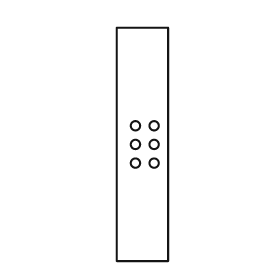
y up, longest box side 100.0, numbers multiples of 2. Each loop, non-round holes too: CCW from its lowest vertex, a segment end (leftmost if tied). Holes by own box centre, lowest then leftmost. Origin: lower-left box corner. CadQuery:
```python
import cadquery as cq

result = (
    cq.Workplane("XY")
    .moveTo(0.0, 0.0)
    .lineTo(22.0, 0.0)
    .lineTo(22.0, 100.0)
    .lineTo(0.0, 100.0)
    .close()
    .moveTo(8.0, 42.0)
    .circle(2.0)
    .moveTo(16.0, 42.0)
    .circle(2.0)
    .moveTo(8.0, 50.0)
    .circle(2.0)
    .moveTo(16.0, 50.0)
    .circle(2.0)
    .moveTo(8.0, 58.0)
    .circle(2.0)
    .moveTo(16.0, 58.0)
    .circle(2.0)
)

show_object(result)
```